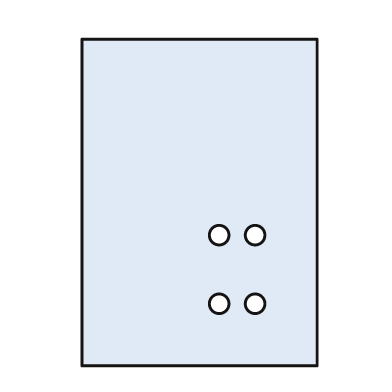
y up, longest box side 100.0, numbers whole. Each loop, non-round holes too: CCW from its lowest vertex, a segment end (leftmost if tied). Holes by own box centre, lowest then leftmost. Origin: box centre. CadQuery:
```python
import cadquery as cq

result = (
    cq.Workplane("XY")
    .moveTo(-36.0, -50.0)
    .lineTo(36.0, -50.0)
    .lineTo(36.0, 50.0)
    .lineTo(-36.0, 50.0)
    .close()
    .moveTo(6.0, -31.0)
    .circle(3.0)
    .moveTo(17.0, -31.0)
    .circle(3.0)
    .moveTo(6.0, -10.0)
    .circle(3.0)
    .moveTo(17.0, -10.0)
    .circle(3.0)
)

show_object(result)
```